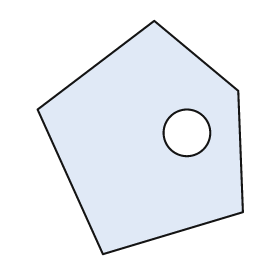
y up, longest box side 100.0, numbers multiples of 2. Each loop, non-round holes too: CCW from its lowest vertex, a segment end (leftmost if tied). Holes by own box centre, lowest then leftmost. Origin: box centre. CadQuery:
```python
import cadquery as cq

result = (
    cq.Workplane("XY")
    .moveTo(-16.0, -50.0)
    .lineTo(44.0, -32.0)
    .lineTo(42.0, 20.0)
    .lineTo(6.0, 50.0)
    .lineTo(-44.0, 12.0)
    .close()
    .moveTo(20.0, 2.0)
    .circle(10.0)
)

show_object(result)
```